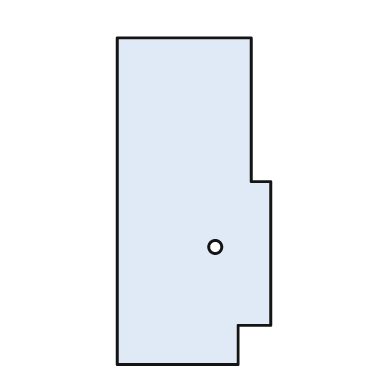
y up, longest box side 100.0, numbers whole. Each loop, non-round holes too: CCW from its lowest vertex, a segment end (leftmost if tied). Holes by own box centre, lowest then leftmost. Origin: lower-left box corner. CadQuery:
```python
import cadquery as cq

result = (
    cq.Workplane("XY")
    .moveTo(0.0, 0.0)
    .lineTo(37.0, 0.0)
    .lineTo(37.0, 12.0)
    .lineTo(47.0, 12.0)
    .lineTo(47.0, 56.0)
    .lineTo(41.0, 56.0)
    .lineTo(41.0, 100.0)
    .lineTo(0.0, 100.0)
    .close()
    .moveTo(30.0, 36.0)
    .circle(2.0)
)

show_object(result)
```